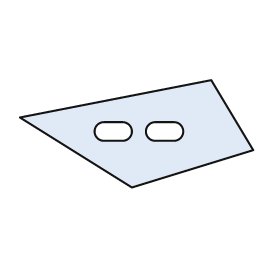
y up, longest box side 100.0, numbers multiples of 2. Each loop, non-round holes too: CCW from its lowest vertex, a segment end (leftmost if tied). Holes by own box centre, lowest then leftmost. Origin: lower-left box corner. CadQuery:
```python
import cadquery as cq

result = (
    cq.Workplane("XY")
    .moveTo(48.0, 0.0)
    .lineTo(100.0, 16.0)
    .lineTo(82.0, 46.0)
    .lineTo(0.0, 30.0)
    .close()
    .moveTo(36.0, 20.0)
    .lineTo(44.0, 20.0)
    .threePointArc((48.0, 24.0), (44.0, 28.0))
    .lineTo(36.0, 28.0)
    .threePointArc((32.0, 24.0), (36.0, 20.0))
    .close()
    .moveTo(58.0, 20.0)
    .lineTo(66.0, 20.0)
    .threePointArc((70.0, 24.0), (66.0, 28.0))
    .lineTo(58.0, 28.0)
    .threePointArc((54.0, 24.0), (58.0, 20.0))
    .close()
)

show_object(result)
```